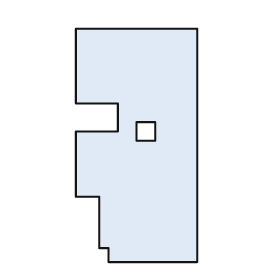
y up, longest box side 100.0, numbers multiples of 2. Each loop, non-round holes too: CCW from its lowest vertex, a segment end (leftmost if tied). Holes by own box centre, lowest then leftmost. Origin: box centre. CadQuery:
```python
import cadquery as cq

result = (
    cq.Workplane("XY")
    .moveTo(-12.0, -50.0)
    .lineTo(26.0, -50.0)
    .lineTo(26.0, 50.0)
    .lineTo(-26.0, 50.0)
    .lineTo(-26.0, 18.0)
    .lineTo(-8.0, 18.0)
    .lineTo(-8.0, 6.0)
    .lineTo(-26.0, 6.0)
    .lineTo(-26.0, -22.0)
    .lineTo(-16.0, -22.0)
    .lineTo(-16.0, -44.0)
    .lineTo(-12.0, -44.0)
    .close()
    .moveTo(0.0, 2.0)
    .lineTo(8.0, 2.0)
    .lineTo(8.0, 10.0)
    .lineTo(0.0, 10.0)
    .close()
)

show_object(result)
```